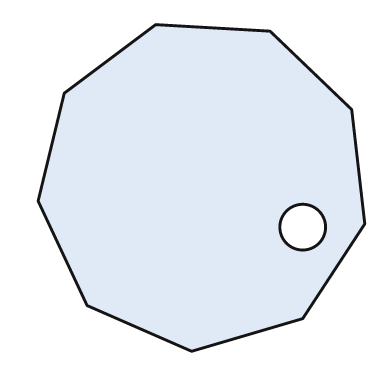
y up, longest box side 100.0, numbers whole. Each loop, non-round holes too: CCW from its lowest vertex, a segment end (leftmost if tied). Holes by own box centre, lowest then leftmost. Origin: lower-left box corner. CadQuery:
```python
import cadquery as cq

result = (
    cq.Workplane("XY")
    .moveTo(47.0, 0.0)
    .lineTo(81.0, 10.0)
    .lineTo(100.0, 39.0)
    .lineTo(96.0, 74.0)
    .lineTo(71.0, 98.0)
    .lineTo(36.0, 100.0)
    .lineTo(8.0, 79.0)
    .lineTo(0.0, 46.0)
    .lineTo(15.0, 14.0)
    .close()
    .moveTo(81.0, 38.0)
    .circle(7.0)
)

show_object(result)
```